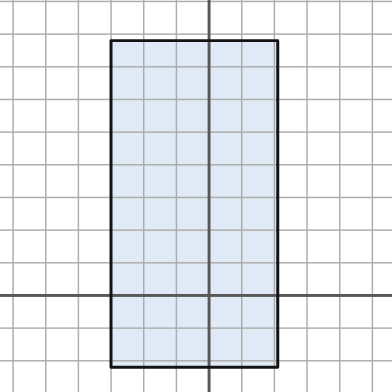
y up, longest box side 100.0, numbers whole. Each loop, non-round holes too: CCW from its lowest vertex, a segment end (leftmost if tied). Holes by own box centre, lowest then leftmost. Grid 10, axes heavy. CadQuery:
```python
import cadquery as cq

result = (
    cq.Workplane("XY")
    .moveTo(-30.0, -22.0)
    .lineTo(21.0, -22.0)
    .lineTo(21.0, 78.0)
    .lineTo(-30.0, 78.0)
    .close()
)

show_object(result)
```